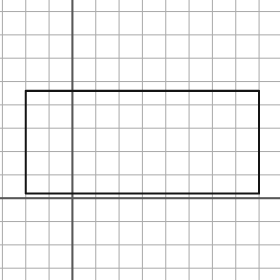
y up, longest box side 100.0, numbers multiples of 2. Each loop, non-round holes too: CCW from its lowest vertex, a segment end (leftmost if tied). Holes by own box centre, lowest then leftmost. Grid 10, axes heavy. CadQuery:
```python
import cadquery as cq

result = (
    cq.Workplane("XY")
    .moveTo(-20.0, 2.0)
    .lineTo(80.0, 2.0)
    .lineTo(80.0, 46.0)
    .lineTo(-20.0, 46.0)
    .close()
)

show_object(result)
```